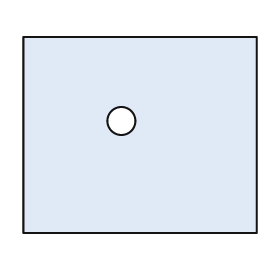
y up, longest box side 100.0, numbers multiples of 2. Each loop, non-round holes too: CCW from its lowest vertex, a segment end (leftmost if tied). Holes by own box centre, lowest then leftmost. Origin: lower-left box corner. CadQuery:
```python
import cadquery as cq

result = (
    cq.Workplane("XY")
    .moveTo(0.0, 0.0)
    .lineTo(100.0, 0.0)
    .lineTo(100.0, 84.0)
    .lineTo(0.0, 84.0)
    .close()
    .moveTo(42.0, 48.0)
    .circle(6.0)
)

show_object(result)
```